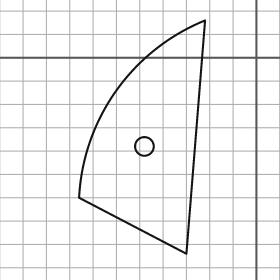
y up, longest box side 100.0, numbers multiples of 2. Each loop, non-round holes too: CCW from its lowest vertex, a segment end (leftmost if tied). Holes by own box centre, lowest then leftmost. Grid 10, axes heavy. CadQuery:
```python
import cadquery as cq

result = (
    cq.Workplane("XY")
    .moveTo(-30.0, -84.0)
    .lineTo(-22.0, 16.0)
    .threePointArc((-60.0, -14.0), (-76.0, -60.0))
    .close()
    .moveTo(-48.0, -38.0)
    .circle(4.0)
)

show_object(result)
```